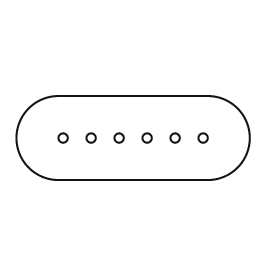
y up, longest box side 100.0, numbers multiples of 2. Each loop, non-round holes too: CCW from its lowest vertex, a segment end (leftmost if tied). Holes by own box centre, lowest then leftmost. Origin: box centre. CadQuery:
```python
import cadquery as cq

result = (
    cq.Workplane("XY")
    .moveTo(-32.0, -18.0)
    .lineTo(32.0, -18.0)
    .threePointArc((50.0, 0.0), (32.0, 18.0))
    .lineTo(-32.0, 18.0)
    .threePointArc((-50.0, 0.0), (-32.0, -18.0))
    .close()
    .moveTo(-30.0, 0.0)
    .circle(2.0)
    .moveTo(-18.0, 0.0)
    .circle(2.0)
    .moveTo(-6.0, 0.0)
    .circle(2.0)
    .moveTo(6.0, 0.0)
    .circle(2.0)
    .moveTo(18.0, 0.0)
    .circle(2.0)
    .moveTo(30.0, 0.0)
    .circle(2.0)
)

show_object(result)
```